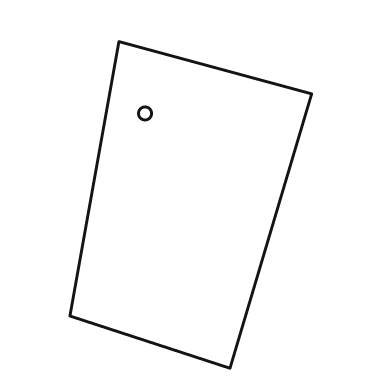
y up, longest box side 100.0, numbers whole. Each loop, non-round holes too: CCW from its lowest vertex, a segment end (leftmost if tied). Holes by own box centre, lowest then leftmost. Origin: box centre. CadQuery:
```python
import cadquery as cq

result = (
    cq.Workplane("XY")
    .moveTo(12.0, -50.0)
    .lineTo(37.0, 34.0)
    .lineTo(-22.0, 50.0)
    .lineTo(-37.0, -34.0)
    .close()
    .moveTo(-14.0, 28.0)
    .circle(2.0)
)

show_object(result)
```